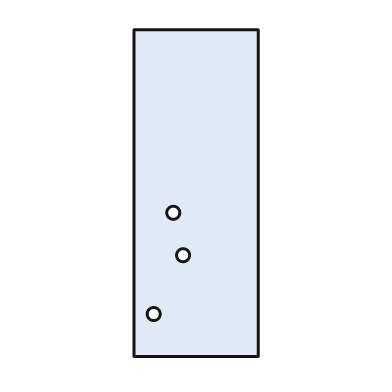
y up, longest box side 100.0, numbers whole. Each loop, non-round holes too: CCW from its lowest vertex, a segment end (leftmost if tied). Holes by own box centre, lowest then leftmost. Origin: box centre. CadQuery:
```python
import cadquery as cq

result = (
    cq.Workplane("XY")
    .moveTo(-19.0, -50.0)
    .lineTo(19.0, -50.0)
    .lineTo(19.0, 50.0)
    .lineTo(-19.0, 50.0)
    .close()
    .moveTo(-13.0, -37.0)
    .circle(2.0)
    .moveTo(-4.0, -19.0)
    .circle(2.0)
    .moveTo(-7.0, -6.0)
    .circle(2.0)
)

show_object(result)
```